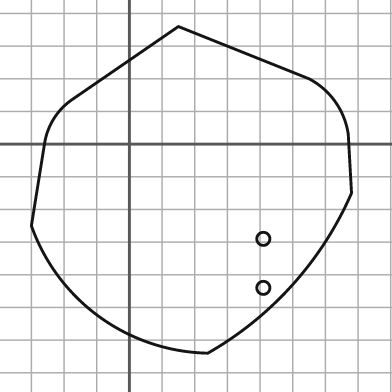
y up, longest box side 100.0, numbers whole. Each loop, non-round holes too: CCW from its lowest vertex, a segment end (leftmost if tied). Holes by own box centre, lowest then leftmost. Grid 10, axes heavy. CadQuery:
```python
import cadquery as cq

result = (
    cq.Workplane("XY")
    .moveTo(24.0, -64.0)
    .threePointArc((50.0, -43.0), (68.0, -15.0))
    .lineTo(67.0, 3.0)
    .threePointArc((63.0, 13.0), (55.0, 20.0))
    .lineTo(15.0, 36.0)
    .lineTo(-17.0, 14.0)
    .threePointArc((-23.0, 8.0), (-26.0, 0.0))
    .lineTo(-30.0, -25.0)
    .threePointArc((-9.0, -53.0), (24.0, -64.0))
    .close()
    .moveTo(41.0, -44.0)
    .circle(2.0)
    .moveTo(41.0, -29.0)
    .circle(2.0)
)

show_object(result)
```